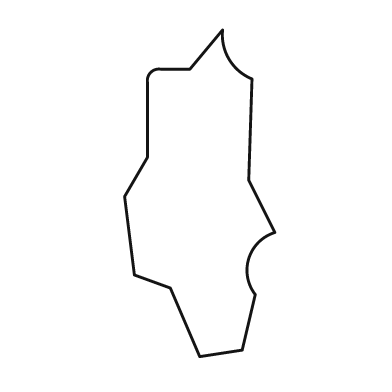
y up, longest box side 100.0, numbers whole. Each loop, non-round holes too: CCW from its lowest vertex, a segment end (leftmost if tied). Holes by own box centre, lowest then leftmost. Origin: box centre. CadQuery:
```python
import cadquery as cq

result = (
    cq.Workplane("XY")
    .moveTo(0.0, -50.0)
    .lineTo(13.0, -48.0)
    .lineTo(17.0, -31.0)
    .threePointArc((15.0, -20.0), (23.0, -12.0))
    .lineTo(15.0, 4.0)
    .lineTo(16.0, 35.0)
    .threePointArc((9.0, 41.0), (7.0, 50.0))
    .lineTo(-3.0, 38.0)
    .lineTo(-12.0, 38.0)
    .threePointArc((-15.0, 37.0), (-16.0, 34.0))
    .lineTo(-16.0, 11.0)
    .lineTo(-23.0, -1.0)
    .lineTo(-20.0, -25.0)
    .lineTo(-9.0, -29.0)
    .close()
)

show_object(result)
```